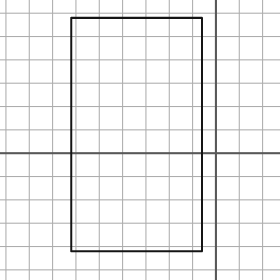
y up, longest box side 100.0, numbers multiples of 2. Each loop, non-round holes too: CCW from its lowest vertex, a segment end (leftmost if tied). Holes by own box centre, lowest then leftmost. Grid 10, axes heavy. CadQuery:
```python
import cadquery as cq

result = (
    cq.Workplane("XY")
    .moveTo(-62.0, -42.0)
    .lineTo(-6.0, -42.0)
    .lineTo(-6.0, 58.0)
    .lineTo(-62.0, 58.0)
    .close()
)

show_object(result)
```